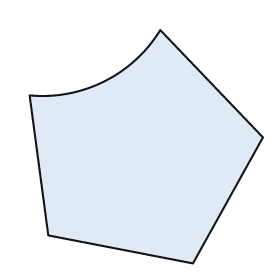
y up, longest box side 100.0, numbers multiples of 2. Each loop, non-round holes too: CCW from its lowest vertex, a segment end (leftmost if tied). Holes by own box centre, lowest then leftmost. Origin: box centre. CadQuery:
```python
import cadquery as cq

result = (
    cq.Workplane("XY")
    .moveTo(20.0, -50.0)
    .lineTo(50.0, 4.0)
    .lineTo(6.0, 50.0)
    .threePointArc((-18.0, 28.0), (-50.0, 22.0))
    .lineTo(-42.0, -38.0)
    .close()
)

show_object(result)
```